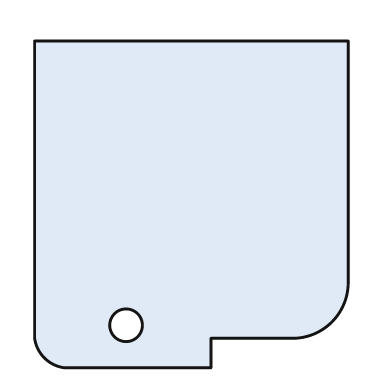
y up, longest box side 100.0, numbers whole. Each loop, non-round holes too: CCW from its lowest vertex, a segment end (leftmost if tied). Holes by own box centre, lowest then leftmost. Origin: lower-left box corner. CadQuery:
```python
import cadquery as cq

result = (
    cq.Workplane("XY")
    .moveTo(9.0, 0.0)
    .lineTo(54.0, 0.0)
    .lineTo(54.0, 9.0)
    .lineTo(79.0, 9.0)
    .threePointArc((91.0, 14.0), (96.0, 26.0))
    .lineTo(96.0, 100.0)
    .lineTo(0.0, 100.0)
    .lineTo(0.0, 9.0)
    .threePointArc((3.0, 3.0), (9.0, 0.0))
    .close()
    .moveTo(28.0, 13.0)
    .circle(5.0)
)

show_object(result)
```